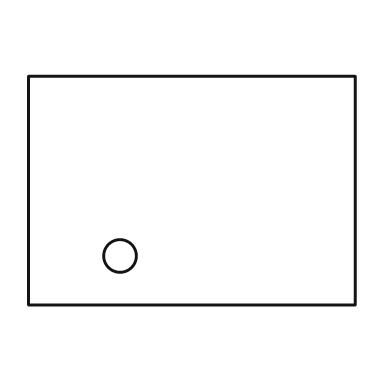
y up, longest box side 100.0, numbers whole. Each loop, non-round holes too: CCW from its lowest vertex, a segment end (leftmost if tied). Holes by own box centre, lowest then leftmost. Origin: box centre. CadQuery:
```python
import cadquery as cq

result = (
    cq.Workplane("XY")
    .moveTo(-50.0, -35.0)
    .lineTo(50.0, -35.0)
    .lineTo(50.0, 35.0)
    .lineTo(-50.0, 35.0)
    .close()
    .moveTo(-22.0, -20.0)
    .circle(5.0)
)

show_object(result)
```